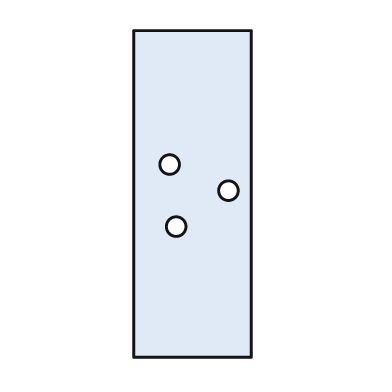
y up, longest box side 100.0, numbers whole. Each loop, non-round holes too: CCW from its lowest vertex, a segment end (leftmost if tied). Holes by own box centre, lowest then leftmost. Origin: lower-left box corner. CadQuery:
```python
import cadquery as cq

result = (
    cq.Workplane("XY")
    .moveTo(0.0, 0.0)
    .lineTo(36.0, 0.0)
    .lineTo(36.0, 100.0)
    .lineTo(0.0, 100.0)
    .close()
    .moveTo(13.0, 40.0)
    .circle(3.0)
    .moveTo(29.0, 51.0)
    .circle(3.0)
    .moveTo(11.0, 59.0)
    .circle(3.0)
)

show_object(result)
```